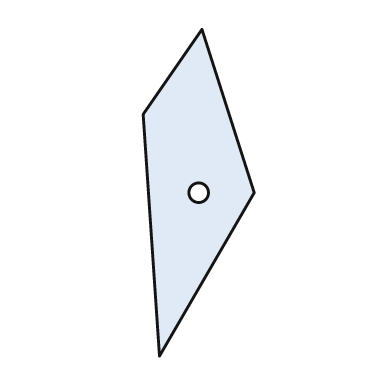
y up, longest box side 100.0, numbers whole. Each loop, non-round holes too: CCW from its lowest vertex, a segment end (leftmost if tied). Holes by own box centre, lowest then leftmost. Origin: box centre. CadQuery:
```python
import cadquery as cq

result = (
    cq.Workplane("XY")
    .moveTo(-12.0, -50.0)
    .lineTo(17.0, 0.0)
    .lineTo(1.0, 50.0)
    .lineTo(-17.0, 24.0)
    .close()
    .moveTo(0.0, 0.0)
    .circle(3.0)
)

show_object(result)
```